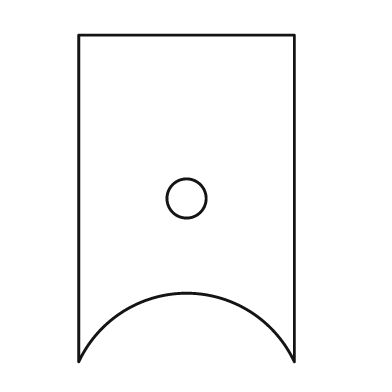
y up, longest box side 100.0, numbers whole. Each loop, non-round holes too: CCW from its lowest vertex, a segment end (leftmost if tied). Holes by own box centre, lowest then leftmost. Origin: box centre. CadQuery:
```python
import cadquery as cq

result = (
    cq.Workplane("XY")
    .moveTo(-33.0, -50.0)
    .threePointArc((0.0, -29.0), (33.0, -50.0))
    .lineTo(33.0, 50.0)
    .lineTo(-33.0, 50.0)
    .close()
    .moveTo(0.0, 0.0)
    .circle(6.0)
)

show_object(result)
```